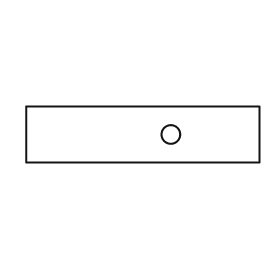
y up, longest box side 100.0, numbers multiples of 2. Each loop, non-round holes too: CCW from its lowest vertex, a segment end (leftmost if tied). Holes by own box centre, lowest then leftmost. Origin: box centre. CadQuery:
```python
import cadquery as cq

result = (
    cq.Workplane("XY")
    .moveTo(-50.0, -12.0)
    .lineTo(50.0, -12.0)
    .lineTo(50.0, 12.0)
    .lineTo(-50.0, 12.0)
    .close()
    .moveTo(12.0, 0.0)
    .circle(4.0)
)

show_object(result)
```